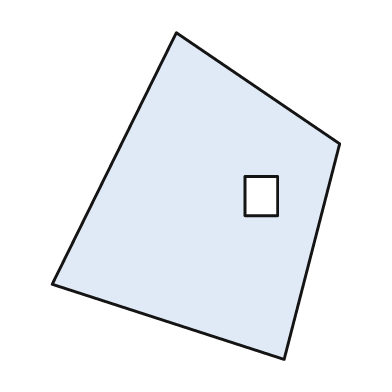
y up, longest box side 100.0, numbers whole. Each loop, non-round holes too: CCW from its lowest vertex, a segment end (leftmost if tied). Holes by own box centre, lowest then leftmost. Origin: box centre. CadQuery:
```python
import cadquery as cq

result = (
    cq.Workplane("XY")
    .moveTo(27.0, -50.0)
    .lineTo(44.0, 16.0)
    .lineTo(-6.0, 50.0)
    .lineTo(-44.0, -27.0)
    .close()
    .moveTo(15.0, -6.0)
    .lineTo(25.0, -6.0)
    .lineTo(25.0, 6.0)
    .lineTo(15.0, 6.0)
    .close()
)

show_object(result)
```